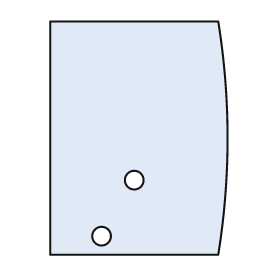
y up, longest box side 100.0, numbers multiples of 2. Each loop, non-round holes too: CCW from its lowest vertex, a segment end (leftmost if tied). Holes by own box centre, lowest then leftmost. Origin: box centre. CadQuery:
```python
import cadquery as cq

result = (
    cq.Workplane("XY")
    .moveTo(-38.0, -50.0)
    .lineTo(34.0, -50.0)
    .threePointArc((38.0, 0.0), (34.0, 50.0))
    .lineTo(-38.0, 50.0)
    .close()
    .moveTo(-16.0, -42.0)
    .circle(4.0)
    .moveTo(-2.0, -18.0)
    .circle(4.0)
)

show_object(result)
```